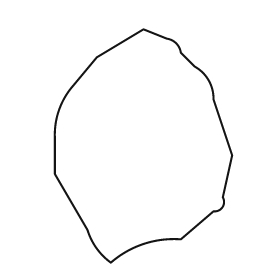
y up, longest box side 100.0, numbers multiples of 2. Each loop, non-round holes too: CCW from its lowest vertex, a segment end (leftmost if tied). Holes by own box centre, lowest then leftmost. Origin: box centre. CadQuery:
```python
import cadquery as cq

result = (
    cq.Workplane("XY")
    .moveTo(-14.0, -50.0)
    .threePointArc((0.0, -42.0), (16.0, -40.0))
    .lineTo(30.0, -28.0)
    .threePointArc((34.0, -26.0), (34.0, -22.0))
    .lineTo(38.0, -4.0)
    .lineTo(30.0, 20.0)
    .threePointArc((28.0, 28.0), (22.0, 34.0))
    .lineTo(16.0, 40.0)
    .threePointArc((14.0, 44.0), (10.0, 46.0))
    .lineTo(0.0, 50.0)
    .lineTo(-20.0, 38.0)
    .lineTo(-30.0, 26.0)
    .threePointArc((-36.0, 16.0), (-38.0, 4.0))
    .lineTo(-38.0, -12.0)
    .lineTo(-24.0, -36.0)
    .threePointArc((-20.0, -44.0), (-14.0, -50.0))
    .close()
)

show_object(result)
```